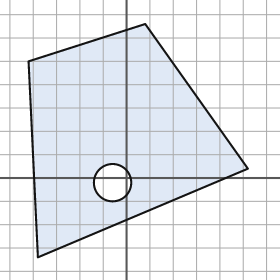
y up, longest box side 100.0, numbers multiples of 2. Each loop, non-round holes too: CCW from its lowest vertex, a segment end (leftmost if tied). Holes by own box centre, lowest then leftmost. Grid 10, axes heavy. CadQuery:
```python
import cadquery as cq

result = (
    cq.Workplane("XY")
    .moveTo(-38.0, -34.0)
    .lineTo(52.0, 4.0)
    .lineTo(8.0, 66.0)
    .lineTo(-42.0, 50.0)
    .close()
    .moveTo(-6.0, -2.0)
    .circle(8.0)
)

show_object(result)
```